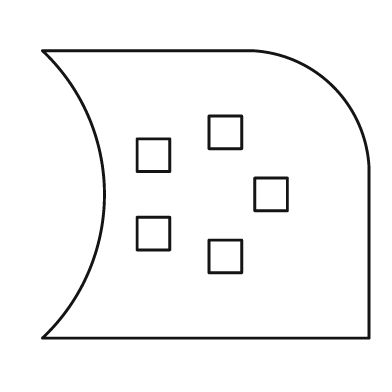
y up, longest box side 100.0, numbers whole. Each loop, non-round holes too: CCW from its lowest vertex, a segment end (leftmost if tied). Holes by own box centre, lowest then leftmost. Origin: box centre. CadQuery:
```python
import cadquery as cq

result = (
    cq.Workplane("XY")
    .moveTo(-50.0, -44.0)
    .lineTo(50.0, -44.0)
    .lineTo(50.0, 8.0)
    .threePointArc((39.0, 33.0), (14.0, 44.0))
    .lineTo(-50.0, 44.0)
    .threePointArc((-31.0, 0.0), (-50.0, -44.0))
    .close()
    .moveTo(1.0, -24.0)
    .lineTo(11.0, -24.0)
    .lineTo(11.0, -14.0)
    .lineTo(1.0, -14.0)
    .close()
    .moveTo(-21.0, -17.0)
    .lineTo(-11.0, -17.0)
    .lineTo(-11.0, -7.0)
    .lineTo(-21.0, -7.0)
    .close()
    .moveTo(15.0, -5.0)
    .lineTo(25.0, -5.0)
    .lineTo(25.0, 5.0)
    .lineTo(15.0, 5.0)
    .close()
    .moveTo(-21.0, 7.0)
    .lineTo(-11.0, 7.0)
    .lineTo(-11.0, 17.0)
    .lineTo(-21.0, 17.0)
    .close()
    .moveTo(1.0, 14.0)
    .lineTo(11.0, 14.0)
    .lineTo(11.0, 24.0)
    .lineTo(1.0, 24.0)
    .close()
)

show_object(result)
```